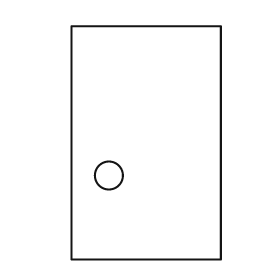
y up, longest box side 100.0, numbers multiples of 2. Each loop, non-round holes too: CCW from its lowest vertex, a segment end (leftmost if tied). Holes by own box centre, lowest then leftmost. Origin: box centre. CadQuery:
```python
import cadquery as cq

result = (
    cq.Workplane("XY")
    .moveTo(-32.0, -50.0)
    .lineTo(32.0, -50.0)
    .lineTo(32.0, 50.0)
    .lineTo(-32.0, 50.0)
    .close()
    .moveTo(-16.0, -14.0)
    .circle(6.0)
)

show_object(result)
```